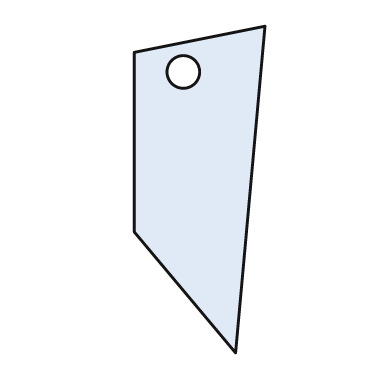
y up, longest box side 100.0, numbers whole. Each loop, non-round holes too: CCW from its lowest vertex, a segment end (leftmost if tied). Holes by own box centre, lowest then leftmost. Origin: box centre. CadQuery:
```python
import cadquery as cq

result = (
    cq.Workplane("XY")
    .moveTo(11.0, -50.0)
    .lineTo(20.0, 50.0)
    .lineTo(-20.0, 42.0)
    .lineTo(-20.0, -13.0)
    .close()
    .moveTo(-5.0, 36.0)
    .circle(5.0)
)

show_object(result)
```